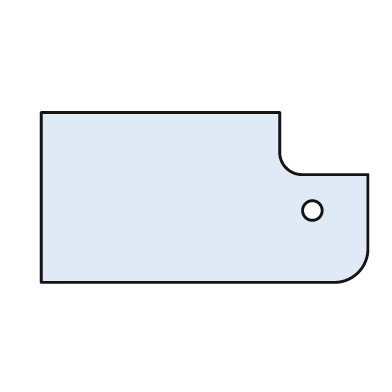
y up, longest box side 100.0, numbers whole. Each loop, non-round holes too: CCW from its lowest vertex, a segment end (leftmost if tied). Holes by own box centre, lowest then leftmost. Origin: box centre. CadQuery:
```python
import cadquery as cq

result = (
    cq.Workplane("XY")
    .moveTo(-50.0, -26.0)
    .lineTo(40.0, -26.0)
    .threePointArc((47.0, -23.0), (50.0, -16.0))
    .lineTo(50.0, 7.0)
    .lineTo(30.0, 7.0)
    .threePointArc((25.0, 9.0), (23.0, 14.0))
    .lineTo(23.0, 26.0)
    .lineTo(-50.0, 26.0)
    .close()
    .moveTo(33.0, -4.0)
    .circle(3.0)
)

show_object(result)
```